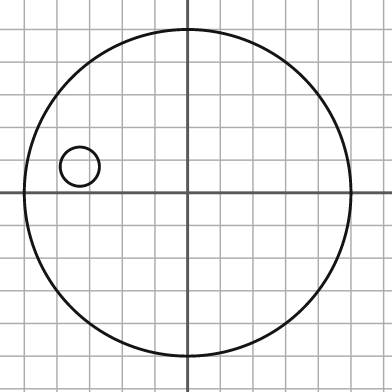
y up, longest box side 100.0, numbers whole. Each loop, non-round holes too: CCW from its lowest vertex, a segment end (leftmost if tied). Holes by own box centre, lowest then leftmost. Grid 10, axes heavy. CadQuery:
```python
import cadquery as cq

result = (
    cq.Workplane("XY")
    .moveTo(0.0, 0.0)
    .circle(50.0)
    .moveTo(-33.0, 8.0)
    .circle(6.0)
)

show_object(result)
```